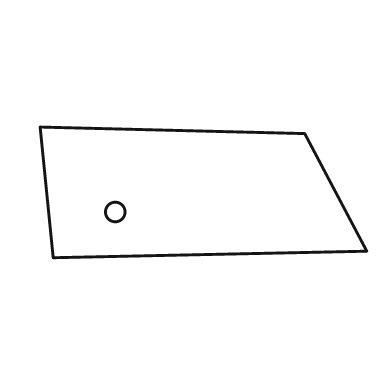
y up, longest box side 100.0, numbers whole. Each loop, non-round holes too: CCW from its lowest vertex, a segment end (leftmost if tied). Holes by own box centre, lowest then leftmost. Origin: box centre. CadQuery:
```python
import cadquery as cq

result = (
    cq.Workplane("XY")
    .moveTo(-46.0, -20.0)
    .lineTo(50.0, -18.0)
    .lineTo(31.0, 18.0)
    .lineTo(-50.0, 20.0)
    .close()
    .moveTo(-27.0, -6.0)
    .circle(3.0)
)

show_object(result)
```